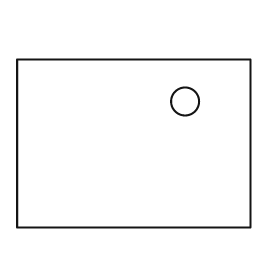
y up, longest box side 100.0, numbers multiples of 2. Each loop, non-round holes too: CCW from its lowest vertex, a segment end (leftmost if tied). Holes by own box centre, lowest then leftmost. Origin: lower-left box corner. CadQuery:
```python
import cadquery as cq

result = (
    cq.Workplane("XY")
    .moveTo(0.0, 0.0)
    .lineTo(100.0, 0.0)
    .lineTo(100.0, 72.0)
    .lineTo(0.0, 72.0)
    .close()
    .moveTo(72.0, 54.0)
    .circle(6.0)
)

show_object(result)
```